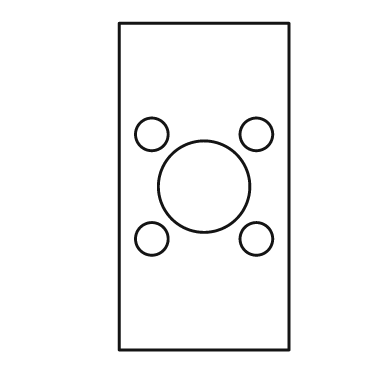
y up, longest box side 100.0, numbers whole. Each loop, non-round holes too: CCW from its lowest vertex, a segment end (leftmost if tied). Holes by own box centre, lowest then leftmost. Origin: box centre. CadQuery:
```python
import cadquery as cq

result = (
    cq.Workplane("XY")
    .moveTo(-26.0, -50.0)
    .lineTo(26.0, -50.0)
    .lineTo(26.0, 50.0)
    .lineTo(-26.0, 50.0)
    .close()
    .moveTo(-16.0, -16.0)
    .circle(5.0)
    .moveTo(16.0, -16.0)
    .circle(5.0)
    .moveTo(0.0, 0.0)
    .circle(14.0)
    .moveTo(-16.0, 16.0)
    .circle(5.0)
    .moveTo(16.0, 16.0)
    .circle(5.0)
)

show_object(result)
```